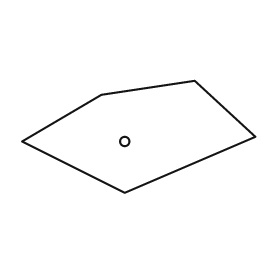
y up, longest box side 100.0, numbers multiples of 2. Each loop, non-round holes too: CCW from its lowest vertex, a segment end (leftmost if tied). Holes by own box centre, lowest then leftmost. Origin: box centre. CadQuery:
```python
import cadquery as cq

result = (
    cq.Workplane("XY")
    .moveTo(-6.0, -24.0)
    .lineTo(50.0, 0.0)
    .lineTo(24.0, 24.0)
    .lineTo(-16.0, 18.0)
    .lineTo(-50.0, -2.0)
    .close()
    .moveTo(-6.0, -2.0)
    .circle(2.0)
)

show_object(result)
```